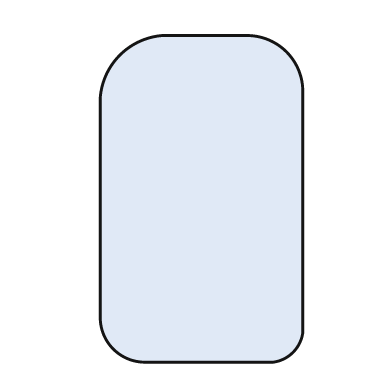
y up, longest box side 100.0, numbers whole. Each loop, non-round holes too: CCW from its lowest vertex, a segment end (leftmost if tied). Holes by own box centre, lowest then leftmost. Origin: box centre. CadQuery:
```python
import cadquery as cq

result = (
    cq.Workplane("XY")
    .moveTo(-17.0, -50.0)
    .lineTo(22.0, -50.0)
    .threePointArc((28.0, -47.0), (31.0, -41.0))
    .lineTo(31.0, 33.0)
    .threePointArc((26.0, 45.0), (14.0, 50.0))
    .lineTo(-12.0, 50.0)
    .threePointArc((-25.0, 44.0), (-31.0, 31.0))
    .lineTo(-31.0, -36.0)
    .threePointArc((-27.0, -46.0), (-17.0, -50.0))
    .close()
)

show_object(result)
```